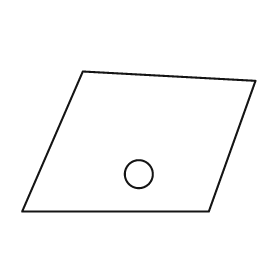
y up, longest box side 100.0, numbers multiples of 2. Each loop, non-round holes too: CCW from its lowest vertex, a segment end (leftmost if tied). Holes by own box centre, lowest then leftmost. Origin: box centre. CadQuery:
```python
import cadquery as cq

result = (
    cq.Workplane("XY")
    .moveTo(-50.0, -30.0)
    .lineTo(30.0, -30.0)
    .lineTo(50.0, 26.0)
    .lineTo(-24.0, 30.0)
    .close()
    .moveTo(0.0, -14.0)
    .circle(6.0)
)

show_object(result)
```